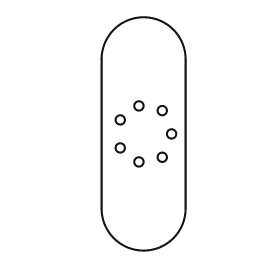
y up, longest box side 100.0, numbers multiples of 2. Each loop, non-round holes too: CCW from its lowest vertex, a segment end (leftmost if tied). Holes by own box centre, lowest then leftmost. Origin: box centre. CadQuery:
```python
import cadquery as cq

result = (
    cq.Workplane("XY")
    .moveTo(-18.0, -32.0)
    .threePointArc((0.0, -50.0), (18.0, -32.0))
    .lineTo(18.0, 32.0)
    .threePointArc((0.0, 50.0), (-18.0, 32.0))
    .close()
    .moveTo(-2.0, -12.0)
    .circle(2.0)
    .moveTo(8.0, -10.0)
    .circle(2.0)
    .moveTo(-10.0, -6.0)
    .circle(2.0)
    .moveTo(12.0, 0.0)
    .circle(2.0)
    .moveTo(-10.0, 6.0)
    .circle(2.0)
    .moveTo(8.0, 10.0)
    .circle(2.0)
    .moveTo(-2.0, 12.0)
    .circle(2.0)
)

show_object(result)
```